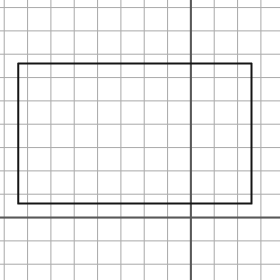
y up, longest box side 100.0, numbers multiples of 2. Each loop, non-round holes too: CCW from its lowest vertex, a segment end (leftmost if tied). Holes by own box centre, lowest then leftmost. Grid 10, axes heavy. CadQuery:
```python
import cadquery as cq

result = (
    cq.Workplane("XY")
    .moveTo(-74.0, 6.0)
    .lineTo(26.0, 6.0)
    .lineTo(26.0, 66.0)
    .lineTo(-74.0, 66.0)
    .close()
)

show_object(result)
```